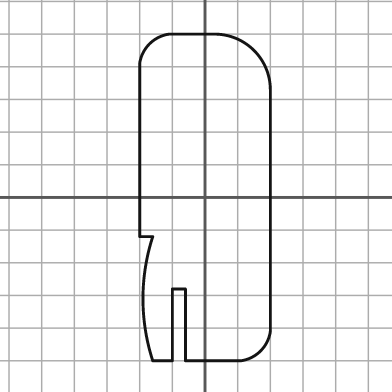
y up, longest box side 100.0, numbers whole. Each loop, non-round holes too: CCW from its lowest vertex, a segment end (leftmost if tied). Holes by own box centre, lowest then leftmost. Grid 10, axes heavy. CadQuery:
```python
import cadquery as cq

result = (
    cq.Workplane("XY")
    .moveTo(-16.0, -50.0)
    .lineTo(-10.0, -50.0)
    .lineTo(-10.0, -28.0)
    .lineTo(-6.0, -28.0)
    .lineTo(-6.0, -50.0)
    .lineTo(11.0, -50.0)
    .threePointArc((17.0, -47.0), (20.0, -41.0))
    .lineTo(20.0, 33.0)
    .threePointArc((15.0, 45.0), (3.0, 50.0))
    .lineTo(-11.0, 50.0)
    .threePointArc((-17.0, 47.0), (-20.0, 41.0))
    .lineTo(-20.0, -12.0)
    .lineTo(-16.0, -12.0)
    .threePointArc((-19.0, -31.0), (-16.0, -50.0))
    .close()
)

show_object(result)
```